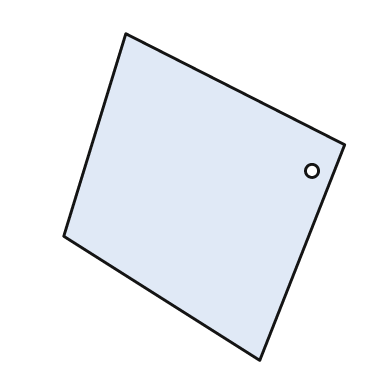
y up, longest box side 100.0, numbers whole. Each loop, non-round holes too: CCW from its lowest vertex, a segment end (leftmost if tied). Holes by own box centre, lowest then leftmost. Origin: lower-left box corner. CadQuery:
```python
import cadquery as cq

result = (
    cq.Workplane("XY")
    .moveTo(60.0, 0.0)
    .lineTo(86.0, 66.0)
    .lineTo(19.0, 100.0)
    .lineTo(0.0, 38.0)
    .close()
    .moveTo(76.0, 58.0)
    .circle(2.0)
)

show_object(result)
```